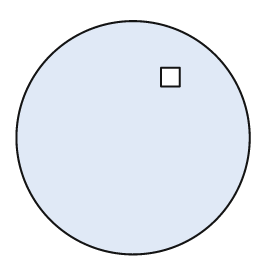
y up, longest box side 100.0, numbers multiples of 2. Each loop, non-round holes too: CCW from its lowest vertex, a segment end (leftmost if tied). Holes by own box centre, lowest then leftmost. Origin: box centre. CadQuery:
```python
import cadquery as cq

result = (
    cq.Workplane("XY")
    .moveTo(0.0, 0.0)
    .circle(50.0)
    .moveTo(12.0, 22.0)
    .lineTo(20.0, 22.0)
    .lineTo(20.0, 30.0)
    .lineTo(12.0, 30.0)
    .close()
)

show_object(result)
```